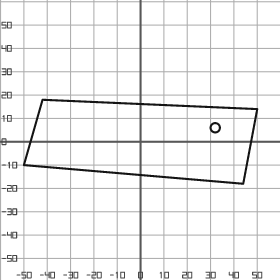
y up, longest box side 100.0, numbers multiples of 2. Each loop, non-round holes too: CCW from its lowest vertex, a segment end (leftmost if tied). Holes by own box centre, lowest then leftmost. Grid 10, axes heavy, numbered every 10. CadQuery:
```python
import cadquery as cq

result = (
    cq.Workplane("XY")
    .moveTo(44.0, -18.0)
    .lineTo(50.0, 14.0)
    .lineTo(-42.0, 18.0)
    .lineTo(-50.0, -10.0)
    .close()
    .moveTo(32.0, 6.0)
    .circle(2.0)
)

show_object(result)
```